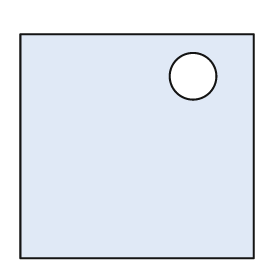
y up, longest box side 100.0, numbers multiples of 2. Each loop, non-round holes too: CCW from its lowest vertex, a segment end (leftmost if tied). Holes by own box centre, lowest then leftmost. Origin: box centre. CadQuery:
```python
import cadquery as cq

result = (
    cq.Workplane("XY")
    .moveTo(-50.0, -48.0)
    .lineTo(50.0, -48.0)
    .lineTo(50.0, 48.0)
    .lineTo(-50.0, 48.0)
    .close()
    .moveTo(24.0, 30.0)
    .circle(10.0)
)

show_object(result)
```